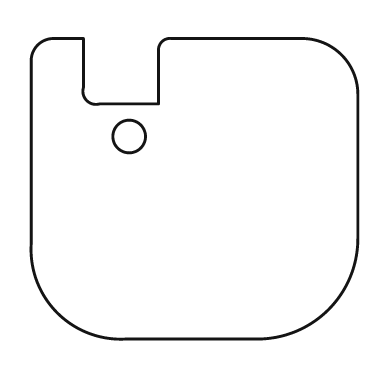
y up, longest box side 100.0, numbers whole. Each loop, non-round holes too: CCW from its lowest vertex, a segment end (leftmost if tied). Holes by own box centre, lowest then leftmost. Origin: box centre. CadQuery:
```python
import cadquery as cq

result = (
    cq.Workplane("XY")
    .moveTo(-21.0, -46.0)
    .lineTo(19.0, -46.0)
    .threePointArc((41.0, -37.0), (50.0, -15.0))
    .lineTo(50.0, 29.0)
    .threePointArc((45.0, 41.0), (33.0, 46.0))
    .lineTo(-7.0, 46.0)
    .threePointArc((-10.0, 45.0), (-11.0, 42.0))
    .lineTo(-11.0, 26.0)
    .lineTo(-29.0, 26.0)
    .threePointArc((-33.0, 27.0), (-34.0, 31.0))
    .lineTo(-34.0, 46.0)
    .lineTo(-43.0, 46.0)
    .threePointArc((-48.0, 44.0), (-50.0, 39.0))
    .lineTo(-50.0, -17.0)
    .threePointArc((-42.0, -38.0), (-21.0, -46.0))
    .close()
    .moveTo(-20.0, 16.0)
    .circle(5.0)
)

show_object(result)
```